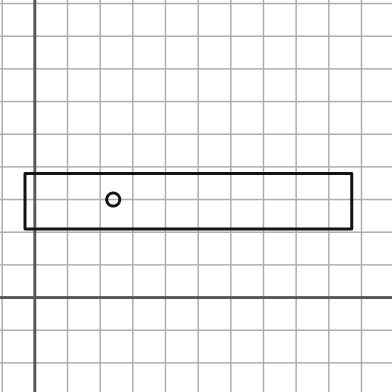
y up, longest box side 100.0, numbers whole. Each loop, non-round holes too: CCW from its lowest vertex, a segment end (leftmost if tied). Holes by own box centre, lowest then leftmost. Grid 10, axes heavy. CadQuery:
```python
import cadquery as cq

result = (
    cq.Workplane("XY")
    .moveTo(-3.0, 21.0)
    .lineTo(97.0, 21.0)
    .lineTo(97.0, 38.0)
    .lineTo(-3.0, 38.0)
    .close()
    .moveTo(24.0, 30.0)
    .circle(2.0)
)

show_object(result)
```